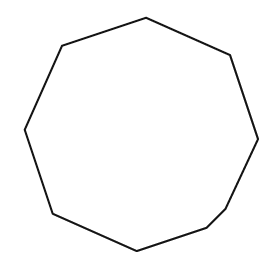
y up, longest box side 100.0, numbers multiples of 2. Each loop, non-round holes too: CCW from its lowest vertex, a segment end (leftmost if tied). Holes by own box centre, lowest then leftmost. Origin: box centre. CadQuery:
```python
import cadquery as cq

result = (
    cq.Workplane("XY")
    .moveTo(-2.0, -50.0)
    .lineTo(28.0, -40.0)
    .lineTo(36.0, -32.0)
    .lineTo(50.0, -2.0)
    .lineTo(38.0, 34.0)
    .lineTo(2.0, 50.0)
    .lineTo(-34.0, 38.0)
    .lineTo(-50.0, 2.0)
    .lineTo(-38.0, -34.0)
    .close()
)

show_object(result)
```